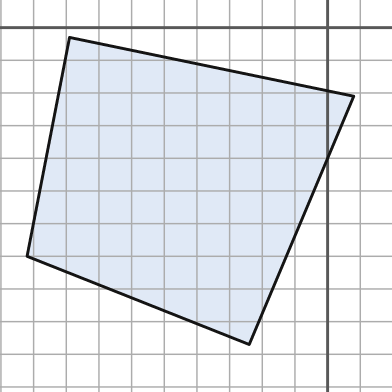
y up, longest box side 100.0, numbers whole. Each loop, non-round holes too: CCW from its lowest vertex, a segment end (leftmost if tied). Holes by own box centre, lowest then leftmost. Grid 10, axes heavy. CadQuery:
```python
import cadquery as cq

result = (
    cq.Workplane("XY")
    .moveTo(-24.0, -97.0)
    .lineTo(8.0, -21.0)
    .lineTo(-79.0, -3.0)
    .lineTo(-92.0, -70.0)
    .close()
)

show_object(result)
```